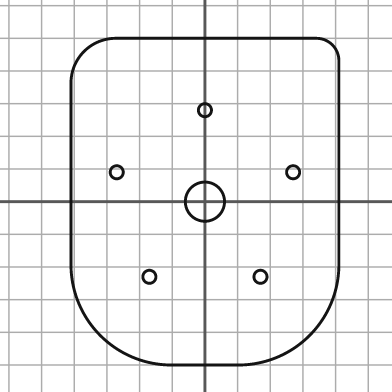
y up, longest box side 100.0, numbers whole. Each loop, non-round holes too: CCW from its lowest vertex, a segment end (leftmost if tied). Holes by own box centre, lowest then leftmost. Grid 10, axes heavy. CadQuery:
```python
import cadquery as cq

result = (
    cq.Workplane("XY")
    .moveTo(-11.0, -50.0)
    .lineTo(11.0, -50.0)
    .threePointArc((32.0, -41.0), (41.0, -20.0))
    .lineTo(41.0, 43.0)
    .threePointArc((39.0, 48.0), (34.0, 50.0))
    .lineTo(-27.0, 50.0)
    .threePointArc((-37.0, 46.0), (-41.0, 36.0))
    .lineTo(-41.0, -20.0)
    .threePointArc((-32.0, -41.0), (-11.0, -50.0))
    .close()
    .moveTo(-17.0, -23.0)
    .circle(2.0)
    .moveTo(17.0, -23.0)
    .circle(2.0)
    .moveTo(0.0, 0.0)
    .circle(6.0)
    .moveTo(-27.0, 9.0)
    .circle(2.0)
    .moveTo(27.0, 9.0)
    .circle(2.0)
    .moveTo(0.0, 28.0)
    .circle(2.0)
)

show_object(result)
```